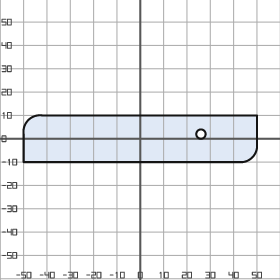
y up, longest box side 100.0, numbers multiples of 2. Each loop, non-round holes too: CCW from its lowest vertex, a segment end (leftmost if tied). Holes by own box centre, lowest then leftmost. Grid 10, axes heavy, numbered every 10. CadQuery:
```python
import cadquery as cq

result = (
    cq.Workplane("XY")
    .moveTo(-50.0, -10.0)
    .lineTo(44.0, -10.0)
    .threePointArc((48.0, -8.0), (50.0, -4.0))
    .lineTo(50.0, 10.0)
    .lineTo(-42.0, 10.0)
    .threePointArc((-48.0, 8.0), (-50.0, 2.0))
    .close()
    .moveTo(26.0, 2.0)
    .circle(2.0)
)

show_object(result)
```